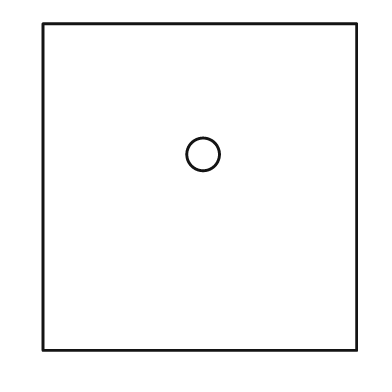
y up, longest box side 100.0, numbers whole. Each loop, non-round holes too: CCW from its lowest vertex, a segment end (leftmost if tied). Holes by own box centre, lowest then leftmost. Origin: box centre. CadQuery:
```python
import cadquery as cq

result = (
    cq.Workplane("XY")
    .moveTo(-48.0, -50.0)
    .lineTo(48.0, -50.0)
    .lineTo(48.0, 50.0)
    .lineTo(-48.0, 50.0)
    .close()
    .moveTo(1.0, 10.0)
    .circle(5.0)
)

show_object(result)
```